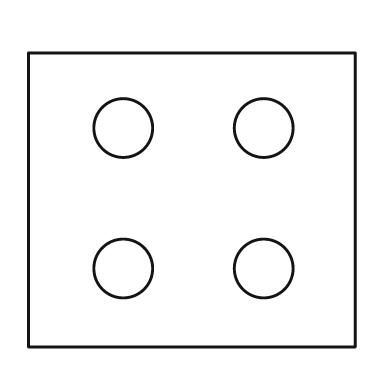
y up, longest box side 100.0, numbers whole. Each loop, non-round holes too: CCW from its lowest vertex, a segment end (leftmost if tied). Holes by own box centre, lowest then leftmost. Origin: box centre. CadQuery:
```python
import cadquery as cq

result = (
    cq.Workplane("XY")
    .moveTo(-50.0, -45.0)
    .lineTo(50.0, -45.0)
    .lineTo(50.0, 45.0)
    .lineTo(-50.0, 45.0)
    .close()
    .moveTo(-21.0, -21.0)
    .circle(9.0)
    .moveTo(22.0, -21.0)
    .circle(9.0)
    .moveTo(-21.0, 22.0)
    .circle(9.0)
    .moveTo(22.0, 22.0)
    .circle(9.0)
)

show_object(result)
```